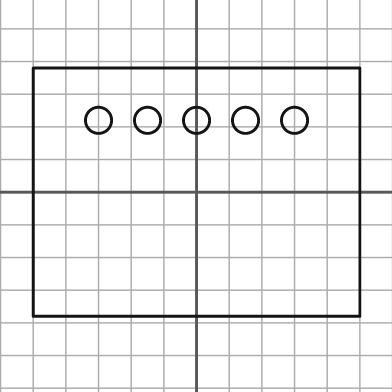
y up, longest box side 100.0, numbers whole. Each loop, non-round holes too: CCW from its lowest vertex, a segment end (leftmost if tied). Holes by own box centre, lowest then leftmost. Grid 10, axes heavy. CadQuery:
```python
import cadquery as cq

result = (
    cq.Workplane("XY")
    .moveTo(-50.0, -38.0)
    .lineTo(50.0, -38.0)
    .lineTo(50.0, 38.0)
    .lineTo(-50.0, 38.0)
    .close()
    .moveTo(-30.0, 22.0)
    .circle(4.0)
    .moveTo(-15.0, 22.0)
    .circle(4.0)
    .moveTo(0.0, 22.0)
    .circle(4.0)
    .moveTo(15.0, 22.0)
    .circle(4.0)
    .moveTo(30.0, 22.0)
    .circle(4.0)
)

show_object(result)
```